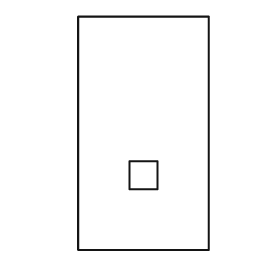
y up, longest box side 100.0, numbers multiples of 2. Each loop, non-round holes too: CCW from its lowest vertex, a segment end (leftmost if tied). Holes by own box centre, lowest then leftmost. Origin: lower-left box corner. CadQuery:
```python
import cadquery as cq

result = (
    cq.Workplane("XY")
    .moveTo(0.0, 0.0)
    .lineTo(56.0, 0.0)
    .lineTo(56.0, 100.0)
    .lineTo(0.0, 100.0)
    .close()
    .moveTo(22.0, 26.0)
    .lineTo(34.0, 26.0)
    .lineTo(34.0, 38.0)
    .lineTo(22.0, 38.0)
    .close()
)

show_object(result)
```